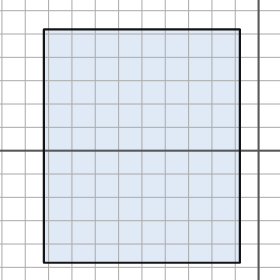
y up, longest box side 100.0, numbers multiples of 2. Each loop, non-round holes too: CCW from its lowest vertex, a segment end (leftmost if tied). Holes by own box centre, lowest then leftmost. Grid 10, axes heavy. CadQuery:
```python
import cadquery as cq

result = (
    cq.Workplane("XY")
    .moveTo(-92.0, -48.0)
    .lineTo(-8.0, -48.0)
    .lineTo(-8.0, 52.0)
    .lineTo(-92.0, 52.0)
    .close()
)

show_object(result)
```